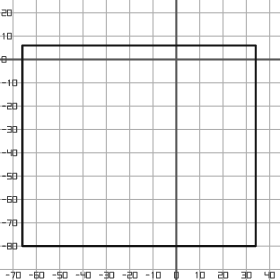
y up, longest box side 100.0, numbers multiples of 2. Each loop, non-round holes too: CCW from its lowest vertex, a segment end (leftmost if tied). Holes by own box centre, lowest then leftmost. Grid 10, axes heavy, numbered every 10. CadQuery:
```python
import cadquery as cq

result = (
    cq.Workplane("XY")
    .moveTo(-66.0, -80.0)
    .lineTo(34.0, -80.0)
    .lineTo(34.0, 6.0)
    .lineTo(-66.0, 6.0)
    .close()
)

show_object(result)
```